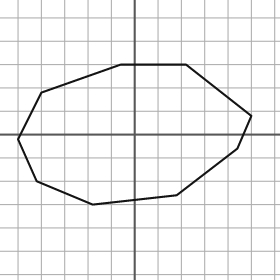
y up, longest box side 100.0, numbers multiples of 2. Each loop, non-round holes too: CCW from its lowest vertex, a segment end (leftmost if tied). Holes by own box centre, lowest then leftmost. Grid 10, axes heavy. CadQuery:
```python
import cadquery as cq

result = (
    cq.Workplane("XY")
    .moveTo(-18.0, -30.0)
    .lineTo(18.0, -26.0)
    .lineTo(44.0, -6.0)
    .lineTo(50.0, 8.0)
    .lineTo(22.0, 30.0)
    .lineTo(-6.0, 30.0)
    .lineTo(-40.0, 18.0)
    .lineTo(-50.0, -2.0)
    .lineTo(-42.0, -20.0)
    .close()
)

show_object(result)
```